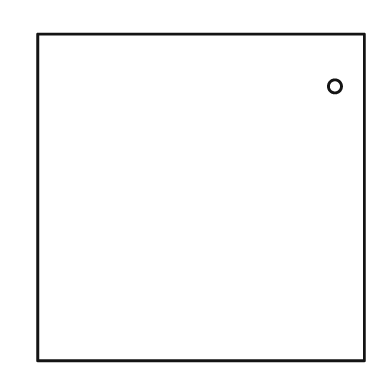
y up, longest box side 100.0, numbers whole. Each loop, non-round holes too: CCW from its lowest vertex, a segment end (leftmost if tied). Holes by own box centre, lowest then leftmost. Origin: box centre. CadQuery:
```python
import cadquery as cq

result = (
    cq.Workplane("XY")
    .moveTo(-50.0, -50.0)
    .lineTo(50.0, -50.0)
    .lineTo(50.0, 50.0)
    .lineTo(-50.0, 50.0)
    .close()
    .moveTo(41.0, 34.0)
    .circle(2.0)
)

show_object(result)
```